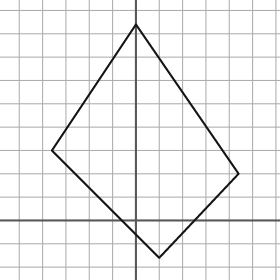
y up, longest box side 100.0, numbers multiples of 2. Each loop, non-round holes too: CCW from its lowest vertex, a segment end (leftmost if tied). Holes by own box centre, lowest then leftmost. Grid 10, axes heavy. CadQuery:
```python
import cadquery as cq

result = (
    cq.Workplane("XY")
    .moveTo(10.0, -16.0)
    .lineTo(44.0, 20.0)
    .lineTo(0.0, 84.0)
    .lineTo(-36.0, 30.0)
    .close()
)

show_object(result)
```